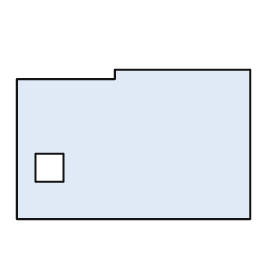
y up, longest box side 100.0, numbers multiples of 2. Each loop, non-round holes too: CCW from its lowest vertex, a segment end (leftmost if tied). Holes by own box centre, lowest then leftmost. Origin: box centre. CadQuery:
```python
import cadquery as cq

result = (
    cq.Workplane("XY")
    .moveTo(-50.0, -32.0)
    .lineTo(50.0, -32.0)
    .lineTo(50.0, 32.0)
    .lineTo(-8.0, 32.0)
    .lineTo(-8.0, 28.0)
    .lineTo(-50.0, 28.0)
    .close()
    .moveTo(-42.0, -16.0)
    .lineTo(-30.0, -16.0)
    .lineTo(-30.0, -4.0)
    .lineTo(-42.0, -4.0)
    .close()
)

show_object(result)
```